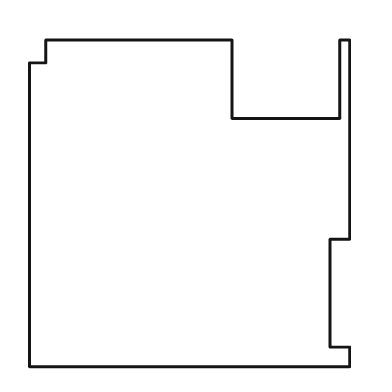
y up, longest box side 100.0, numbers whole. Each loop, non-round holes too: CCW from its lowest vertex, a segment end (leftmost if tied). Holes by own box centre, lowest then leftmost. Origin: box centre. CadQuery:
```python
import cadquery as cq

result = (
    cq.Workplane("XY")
    .moveTo(-49.0, -50.0)
    .lineTo(49.0, -50.0)
    .lineTo(49.0, -44.0)
    .lineTo(43.0, -44.0)
    .lineTo(43.0, -11.0)
    .lineTo(49.0, -11.0)
    .lineTo(49.0, 50.0)
    .lineTo(46.0, 50.0)
    .lineTo(46.0, 26.0)
    .lineTo(13.0, 26.0)
    .lineTo(13.0, 50.0)
    .lineTo(-44.0, 50.0)
    .lineTo(-44.0, 43.0)
    .lineTo(-49.0, 43.0)
    .close()
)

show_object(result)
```